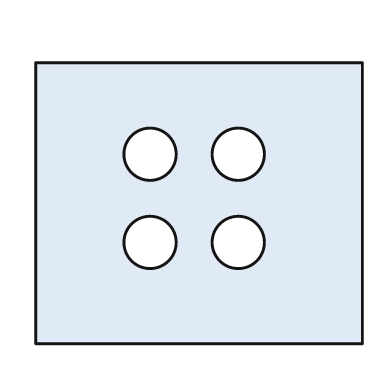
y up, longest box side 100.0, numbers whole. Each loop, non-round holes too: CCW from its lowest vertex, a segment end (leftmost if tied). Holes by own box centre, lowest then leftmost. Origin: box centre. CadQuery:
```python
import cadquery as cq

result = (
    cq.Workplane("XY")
    .moveTo(-50.0, -43.0)
    .lineTo(50.0, -43.0)
    .lineTo(50.0, 43.0)
    .lineTo(-50.0, 43.0)
    .close()
    .moveTo(-15.0, -12.0)
    .circle(8.0)
    .moveTo(12.0, -12.0)
    .circle(8.0)
    .moveTo(-15.0, 15.0)
    .circle(8.0)
    .moveTo(12.0, 15.0)
    .circle(8.0)
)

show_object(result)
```